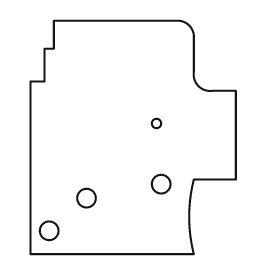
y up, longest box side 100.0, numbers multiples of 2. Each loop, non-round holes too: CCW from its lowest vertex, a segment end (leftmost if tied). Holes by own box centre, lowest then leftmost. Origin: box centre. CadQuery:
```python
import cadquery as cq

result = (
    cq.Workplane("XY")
    .moveTo(-44.0, -50.0)
    .lineTo(26.0, -50.0)
    .threePointArc((24.0, -34.0), (26.0, -18.0))
    .lineTo(44.0, -18.0)
    .lineTo(44.0, 20.0)
    .lineTo(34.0, 20.0)
    .threePointArc((28.0, 22.0), (26.0, 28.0))
    .lineTo(26.0, 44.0)
    .threePointArc((24.0, 48.0), (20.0, 50.0))
    .lineTo(-34.0, 50.0)
    .lineTo(-34.0, 38.0)
    .lineTo(-38.0, 38.0)
    .lineTo(-38.0, 24.0)
    .lineTo(-44.0, 24.0)
    .close()
    .moveTo(-36.0, -40.0)
    .circle(4.0)
    .moveTo(-20.0, -26.0)
    .circle(4.0)
    .moveTo(12.0, -20.0)
    .circle(4.0)
    .moveTo(10.0, 6.0)
    .circle(2.0)
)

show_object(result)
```